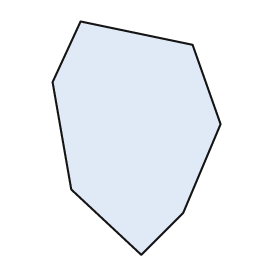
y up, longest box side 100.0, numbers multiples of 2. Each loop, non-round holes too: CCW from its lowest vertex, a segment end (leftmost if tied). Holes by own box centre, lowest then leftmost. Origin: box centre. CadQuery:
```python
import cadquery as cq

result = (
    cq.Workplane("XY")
    .moveTo(2.0, -50.0)
    .lineTo(20.0, -32.0)
    .lineTo(36.0, 6.0)
    .lineTo(24.0, 40.0)
    .lineTo(-24.0, 50.0)
    .lineTo(-36.0, 24.0)
    .lineTo(-28.0, -22.0)
    .close()
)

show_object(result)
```